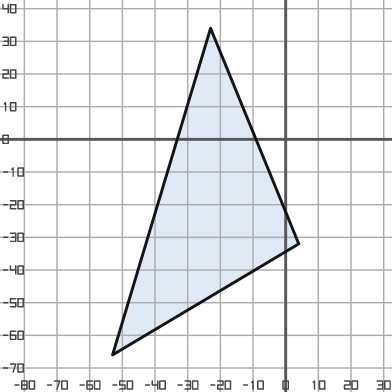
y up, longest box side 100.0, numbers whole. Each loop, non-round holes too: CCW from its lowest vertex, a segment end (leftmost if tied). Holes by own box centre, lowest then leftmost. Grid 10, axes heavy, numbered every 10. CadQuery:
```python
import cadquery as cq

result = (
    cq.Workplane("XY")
    .moveTo(-53.0, -66.0)
    .lineTo(4.0, -32.0)
    .lineTo(-23.0, 34.0)
    .close()
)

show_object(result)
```